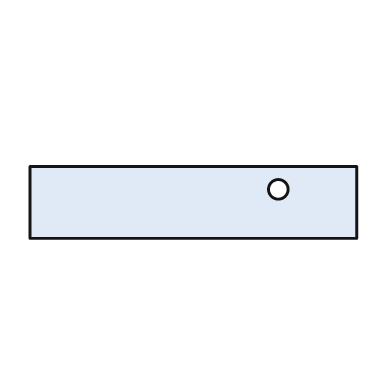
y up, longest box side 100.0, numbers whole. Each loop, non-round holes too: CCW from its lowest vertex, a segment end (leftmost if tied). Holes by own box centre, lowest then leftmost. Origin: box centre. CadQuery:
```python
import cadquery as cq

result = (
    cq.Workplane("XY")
    .moveTo(-50.0, -11.0)
    .lineTo(50.0, -11.0)
    .lineTo(50.0, 11.0)
    .lineTo(-50.0, 11.0)
    .close()
    .moveTo(26.0, 4.0)
    .circle(3.0)
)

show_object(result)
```